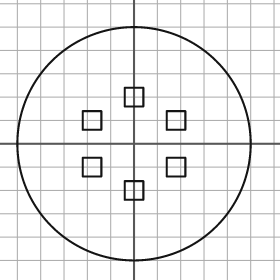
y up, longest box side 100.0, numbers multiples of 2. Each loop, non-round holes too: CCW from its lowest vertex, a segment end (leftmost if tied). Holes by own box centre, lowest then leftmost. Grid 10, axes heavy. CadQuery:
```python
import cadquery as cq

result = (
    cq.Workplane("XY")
    .moveTo(0.0, 0.0)
    .circle(50.0)
    .moveTo(-4.0, -24.0)
    .lineTo(4.0, -24.0)
    .lineTo(4.0, -16.0)
    .lineTo(-4.0, -16.0)
    .close()
    .moveTo(-22.0, -14.0)
    .lineTo(-14.0, -14.0)
    .lineTo(-14.0, -6.0)
    .lineTo(-22.0, -6.0)
    .close()
    .moveTo(14.0, -14.0)
    .lineTo(22.0, -14.0)
    .lineTo(22.0, -6.0)
    .lineTo(14.0, -6.0)
    .close()
    .moveTo(-22.0, 6.0)
    .lineTo(-14.0, 6.0)
    .lineTo(-14.0, 14.0)
    .lineTo(-22.0, 14.0)
    .close()
    .moveTo(14.0, 6.0)
    .lineTo(22.0, 6.0)
    .lineTo(22.0, 14.0)
    .lineTo(14.0, 14.0)
    .close()
    .moveTo(-4.0, 16.0)
    .lineTo(4.0, 16.0)
    .lineTo(4.0, 24.0)
    .lineTo(-4.0, 24.0)
    .close()
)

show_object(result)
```